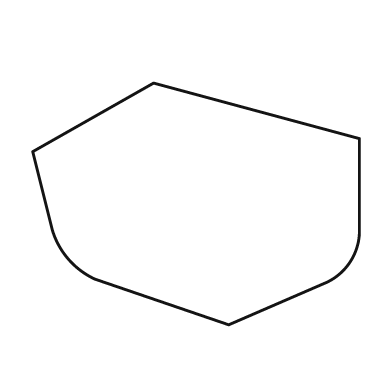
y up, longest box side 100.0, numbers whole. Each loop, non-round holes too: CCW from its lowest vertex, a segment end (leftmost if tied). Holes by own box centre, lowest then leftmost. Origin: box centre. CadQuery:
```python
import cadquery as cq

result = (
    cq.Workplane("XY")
    .moveTo(10.0, -37.0)
    .lineTo(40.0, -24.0)
    .threePointArc((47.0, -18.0), (50.0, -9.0))
    .lineTo(50.0, 20.0)
    .lineTo(-13.0, 37.0)
    .lineTo(-50.0, 16.0)
    .lineTo(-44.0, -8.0)
    .threePointArc((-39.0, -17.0), (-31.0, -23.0))
    .close()
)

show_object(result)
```